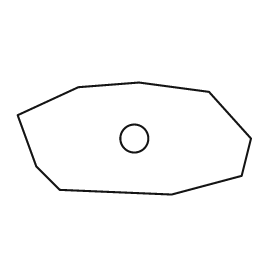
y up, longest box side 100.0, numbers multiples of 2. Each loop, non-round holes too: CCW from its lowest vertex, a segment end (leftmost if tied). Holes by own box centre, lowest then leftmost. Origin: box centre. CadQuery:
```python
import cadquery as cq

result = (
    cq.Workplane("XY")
    .moveTo(16.0, -24.0)
    .lineTo(46.0, -16.0)
    .lineTo(50.0, 0.0)
    .lineTo(32.0, 20.0)
    .lineTo(2.0, 24.0)
    .lineTo(-24.0, 22.0)
    .lineTo(-50.0, 10.0)
    .lineTo(-42.0, -12.0)
    .lineTo(-32.0, -22.0)
    .close()
    .moveTo(0.0, 0.0)
    .circle(6.0)
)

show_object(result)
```